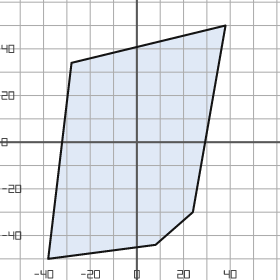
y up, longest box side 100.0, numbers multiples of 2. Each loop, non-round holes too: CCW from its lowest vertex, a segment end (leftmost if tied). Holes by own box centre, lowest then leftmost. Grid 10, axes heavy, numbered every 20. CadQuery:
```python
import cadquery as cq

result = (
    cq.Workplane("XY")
    .moveTo(-38.0, -50.0)
    .lineTo(8.0, -44.0)
    .lineTo(24.0, -30.0)
    .lineTo(38.0, 50.0)
    .lineTo(-28.0, 34.0)
    .close()
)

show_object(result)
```